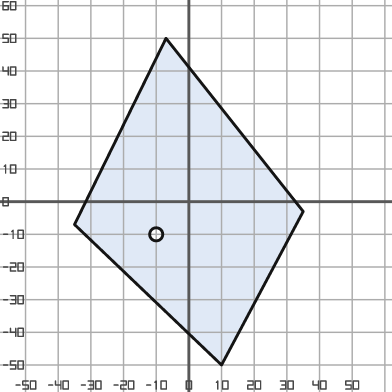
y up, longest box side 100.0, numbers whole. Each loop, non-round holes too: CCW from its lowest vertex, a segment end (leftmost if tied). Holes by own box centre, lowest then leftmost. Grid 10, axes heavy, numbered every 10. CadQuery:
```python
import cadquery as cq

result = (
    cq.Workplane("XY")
    .moveTo(10.0, -50.0)
    .lineTo(35.0, -3.0)
    .lineTo(-7.0, 50.0)
    .lineTo(-35.0, -7.0)
    .close()
    .moveTo(-10.0, -10.0)
    .circle(2.0)
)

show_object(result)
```